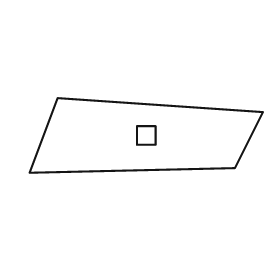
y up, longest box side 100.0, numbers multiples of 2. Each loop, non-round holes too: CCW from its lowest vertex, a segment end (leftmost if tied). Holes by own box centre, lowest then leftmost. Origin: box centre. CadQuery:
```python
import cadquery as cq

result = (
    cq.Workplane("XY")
    .moveTo(-50.0, -16.0)
    .lineTo(38.0, -14.0)
    .lineTo(50.0, 10.0)
    .lineTo(-38.0, 16.0)
    .close()
    .moveTo(-4.0, -4.0)
    .lineTo(4.0, -4.0)
    .lineTo(4.0, 4.0)
    .lineTo(-4.0, 4.0)
    .close()
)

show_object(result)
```